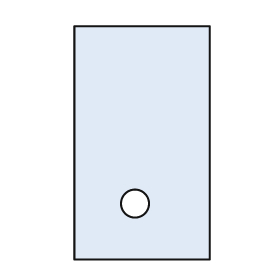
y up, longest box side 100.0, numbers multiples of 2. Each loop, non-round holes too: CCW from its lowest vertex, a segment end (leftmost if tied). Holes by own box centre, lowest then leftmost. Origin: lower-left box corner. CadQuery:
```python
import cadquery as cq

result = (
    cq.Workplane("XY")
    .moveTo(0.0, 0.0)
    .lineTo(58.0, 0.0)
    .lineTo(58.0, 100.0)
    .lineTo(0.0, 100.0)
    .close()
    .moveTo(26.0, 24.0)
    .circle(6.0)
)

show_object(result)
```